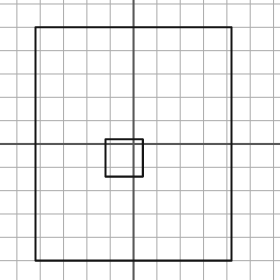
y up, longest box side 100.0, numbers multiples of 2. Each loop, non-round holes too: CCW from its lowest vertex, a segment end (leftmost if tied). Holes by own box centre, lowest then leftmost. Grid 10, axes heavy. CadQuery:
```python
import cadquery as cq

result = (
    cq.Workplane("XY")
    .moveTo(-42.0, -50.0)
    .lineTo(42.0, -50.0)
    .lineTo(42.0, 50.0)
    .lineTo(-42.0, 50.0)
    .close()
    .moveTo(-12.0, -14.0)
    .lineTo(4.0, -14.0)
    .lineTo(4.0, 2.0)
    .lineTo(-12.0, 2.0)
    .close()
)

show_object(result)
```